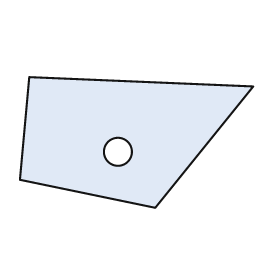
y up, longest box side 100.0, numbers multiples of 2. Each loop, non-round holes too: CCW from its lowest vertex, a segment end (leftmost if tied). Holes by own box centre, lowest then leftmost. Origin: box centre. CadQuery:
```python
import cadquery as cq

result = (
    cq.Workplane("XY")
    .moveTo(8.0, -28.0)
    .lineTo(50.0, 24.0)
    .lineTo(-46.0, 28.0)
    .lineTo(-50.0, -16.0)
    .close()
    .moveTo(-8.0, -4.0)
    .circle(6.0)
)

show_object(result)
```